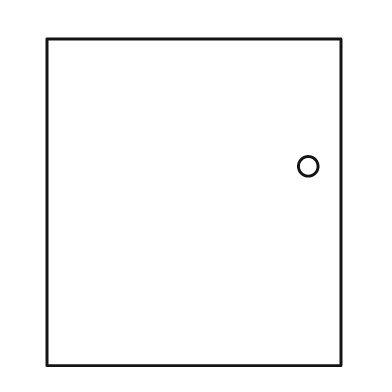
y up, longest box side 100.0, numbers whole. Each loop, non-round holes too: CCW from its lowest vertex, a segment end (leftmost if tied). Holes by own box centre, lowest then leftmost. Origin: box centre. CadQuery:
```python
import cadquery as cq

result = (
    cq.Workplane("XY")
    .moveTo(-45.0, -50.0)
    .lineTo(45.0, -50.0)
    .lineTo(45.0, 50.0)
    .lineTo(-45.0, 50.0)
    .close()
    .moveTo(35.0, 11.0)
    .circle(3.0)
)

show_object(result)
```